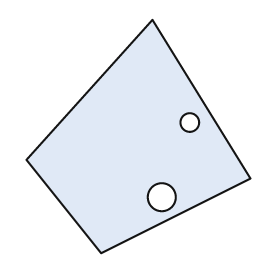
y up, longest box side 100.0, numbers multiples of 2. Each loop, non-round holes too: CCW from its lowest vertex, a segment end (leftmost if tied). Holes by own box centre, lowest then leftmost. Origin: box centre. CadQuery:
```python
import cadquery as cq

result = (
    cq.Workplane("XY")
    .moveTo(-16.0, -50.0)
    .lineTo(48.0, -18.0)
    .lineTo(6.0, 50.0)
    .lineTo(-48.0, -10.0)
    .close()
    .moveTo(10.0, -26.0)
    .circle(6.0)
    .moveTo(22.0, 6.0)
    .circle(4.0)
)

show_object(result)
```